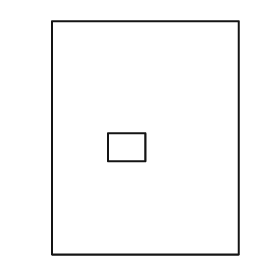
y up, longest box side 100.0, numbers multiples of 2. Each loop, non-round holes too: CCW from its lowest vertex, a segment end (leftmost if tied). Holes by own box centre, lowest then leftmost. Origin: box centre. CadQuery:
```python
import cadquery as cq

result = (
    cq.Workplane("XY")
    .moveTo(-40.0, -50.0)
    .lineTo(40.0, -50.0)
    .lineTo(40.0, 50.0)
    .lineTo(-40.0, 50.0)
    .close()
    .moveTo(-16.0, -10.0)
    .lineTo(0.0, -10.0)
    .lineTo(0.0, 2.0)
    .lineTo(-16.0, 2.0)
    .close()
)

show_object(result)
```